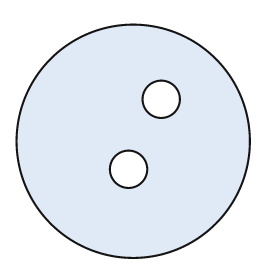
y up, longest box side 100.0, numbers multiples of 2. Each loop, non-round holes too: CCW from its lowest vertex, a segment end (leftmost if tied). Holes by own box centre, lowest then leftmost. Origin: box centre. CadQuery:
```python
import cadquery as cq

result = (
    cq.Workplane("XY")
    .moveTo(0.0, 0.0)
    .circle(50.0)
    .moveTo(-2.0, -12.0)
    .circle(8.0)
    .moveTo(12.0, 18.0)
    .circle(8.0)
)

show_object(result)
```